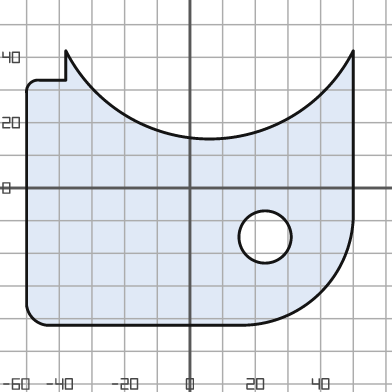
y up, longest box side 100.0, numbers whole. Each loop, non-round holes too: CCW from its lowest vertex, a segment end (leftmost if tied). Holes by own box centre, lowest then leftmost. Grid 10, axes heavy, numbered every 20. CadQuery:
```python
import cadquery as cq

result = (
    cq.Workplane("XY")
    .moveTo(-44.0, -42.0)
    .lineTo(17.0, -42.0)
    .threePointArc((40.0, -32.0), (50.0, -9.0))
    .lineTo(50.0, 42.0)
    .threePointArc((6.0, 15.0), (-38.0, 42.0))
    .lineTo(-38.0, 33.0)
    .lineTo(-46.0, 33.0)
    .threePointArc((-49.0, 32.0), (-50.0, 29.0))
    .lineTo(-50.0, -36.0)
    .threePointArc((-48.0, -40.0), (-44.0, -42.0))
    .close()
    .moveTo(23.0, -15.0)
    .circle(8.0)
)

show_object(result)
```